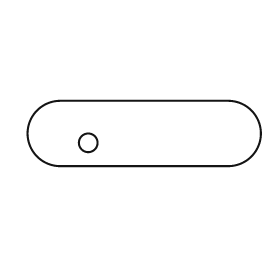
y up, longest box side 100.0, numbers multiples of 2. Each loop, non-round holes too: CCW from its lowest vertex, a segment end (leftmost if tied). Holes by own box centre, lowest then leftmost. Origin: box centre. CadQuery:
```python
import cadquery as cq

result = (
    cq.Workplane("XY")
    .moveTo(-36.0, -14.0)
    .lineTo(36.0, -14.0)
    .threePointArc((50.0, 0.0), (36.0, 14.0))
    .lineTo(-36.0, 14.0)
    .threePointArc((-50.0, 0.0), (-36.0, -14.0))
    .close()
    .moveTo(-24.0, -4.0)
    .circle(4.0)
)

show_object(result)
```